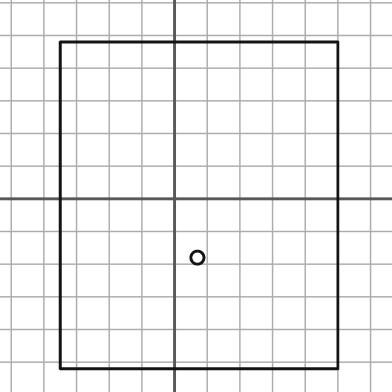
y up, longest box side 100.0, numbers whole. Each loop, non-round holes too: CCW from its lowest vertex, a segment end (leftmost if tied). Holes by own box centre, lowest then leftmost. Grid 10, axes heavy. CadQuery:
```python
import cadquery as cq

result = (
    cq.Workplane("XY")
    .moveTo(-35.0, -52.0)
    .lineTo(50.0, -52.0)
    .lineTo(50.0, 48.0)
    .lineTo(-35.0, 48.0)
    .close()
    .moveTo(7.0, -18.0)
    .circle(2.0)
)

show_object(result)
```